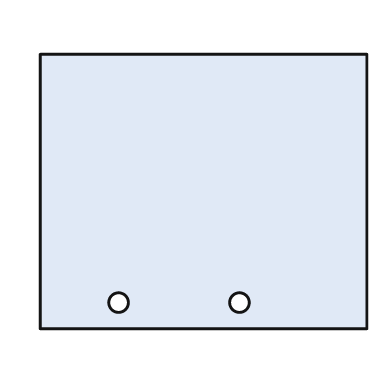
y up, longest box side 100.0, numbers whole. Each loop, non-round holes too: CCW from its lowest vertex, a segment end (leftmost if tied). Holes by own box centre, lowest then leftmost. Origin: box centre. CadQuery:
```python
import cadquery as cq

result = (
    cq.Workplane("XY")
    .moveTo(-50.0, -42.0)
    .lineTo(50.0, -42.0)
    .lineTo(50.0, 42.0)
    .lineTo(-50.0, 42.0)
    .close()
    .moveTo(-26.0, -34.0)
    .circle(3.0)
    .moveTo(11.0, -34.0)
    .circle(3.0)
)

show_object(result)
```